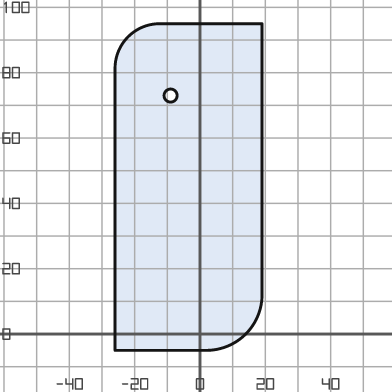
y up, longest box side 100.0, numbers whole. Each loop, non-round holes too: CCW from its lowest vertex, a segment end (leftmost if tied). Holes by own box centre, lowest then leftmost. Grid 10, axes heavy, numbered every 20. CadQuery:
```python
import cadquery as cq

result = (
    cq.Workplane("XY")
    .moveTo(-26.0, -5.0)
    .lineTo(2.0, -5.0)
    .threePointArc((14.0, 0.0), (19.0, 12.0))
    .lineTo(19.0, 95.0)
    .lineTo(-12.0, 95.0)
    .threePointArc((-22.0, 91.0), (-26.0, 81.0))
    .close()
    .moveTo(-9.0, 73.0)
    .circle(2.0)
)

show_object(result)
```